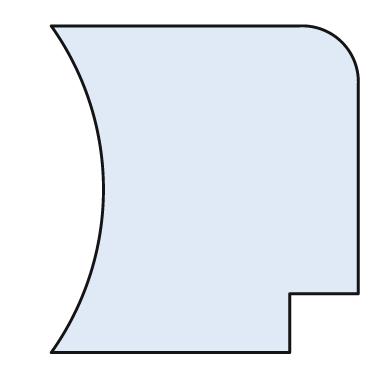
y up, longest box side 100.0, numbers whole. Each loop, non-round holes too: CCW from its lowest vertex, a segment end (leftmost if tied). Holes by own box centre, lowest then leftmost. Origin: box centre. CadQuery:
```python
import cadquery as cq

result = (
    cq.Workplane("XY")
    .moveTo(-47.0, -50.0)
    .lineTo(26.0, -50.0)
    .lineTo(26.0, -32.0)
    .lineTo(47.0, -32.0)
    .lineTo(47.0, 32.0)
    .threePointArc((42.0, 45.0), (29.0, 50.0))
    .lineTo(-47.0, 50.0)
    .threePointArc((-31.0, 0.0), (-47.0, -50.0))
    .close()
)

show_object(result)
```